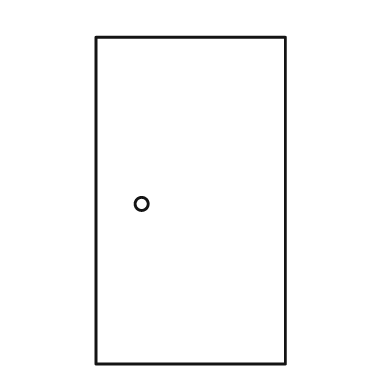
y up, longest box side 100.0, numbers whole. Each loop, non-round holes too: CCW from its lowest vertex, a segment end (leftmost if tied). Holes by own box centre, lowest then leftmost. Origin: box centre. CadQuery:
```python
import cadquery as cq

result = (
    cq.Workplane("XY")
    .moveTo(-29.0, -50.0)
    .lineTo(29.0, -50.0)
    .lineTo(29.0, 50.0)
    .lineTo(-29.0, 50.0)
    .close()
    .moveTo(-15.0, -1.0)
    .circle(2.0)
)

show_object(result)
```